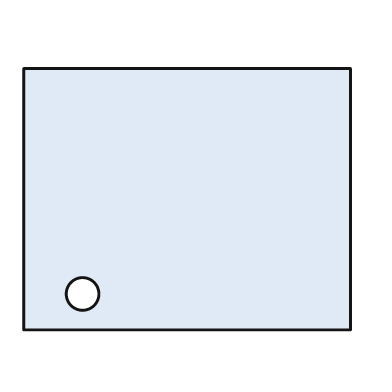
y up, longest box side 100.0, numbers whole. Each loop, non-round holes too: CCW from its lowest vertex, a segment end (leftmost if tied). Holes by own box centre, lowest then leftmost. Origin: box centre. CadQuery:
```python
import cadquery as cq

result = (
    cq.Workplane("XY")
    .moveTo(-50.0, -40.0)
    .lineTo(50.0, -40.0)
    .lineTo(50.0, 40.0)
    .lineTo(-50.0, 40.0)
    .close()
    .moveTo(-32.0, -29.0)
    .circle(5.0)
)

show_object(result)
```